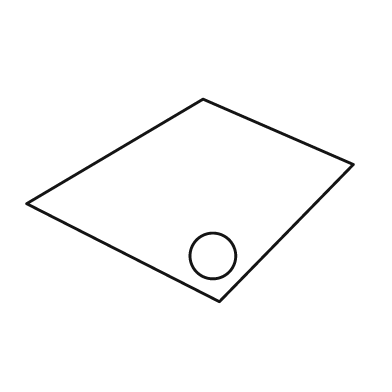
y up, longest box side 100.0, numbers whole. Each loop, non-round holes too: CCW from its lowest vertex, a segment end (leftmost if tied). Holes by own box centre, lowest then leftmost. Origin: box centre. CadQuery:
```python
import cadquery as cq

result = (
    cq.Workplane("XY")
    .moveTo(9.0, -31.0)
    .lineTo(50.0, 11.0)
    .lineTo(4.0, 31.0)
    .lineTo(-50.0, -1.0)
    .close()
    .moveTo(7.0, -17.0)
    .circle(7.0)
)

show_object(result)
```